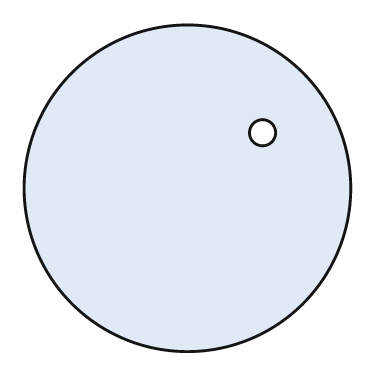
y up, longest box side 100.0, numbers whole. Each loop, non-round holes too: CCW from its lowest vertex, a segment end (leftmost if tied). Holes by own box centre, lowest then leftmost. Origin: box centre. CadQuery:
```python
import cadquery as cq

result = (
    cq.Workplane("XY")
    .moveTo(0.0, 0.0)
    .circle(50.0)
    .moveTo(23.0, 17.0)
    .circle(4.0)
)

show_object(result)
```